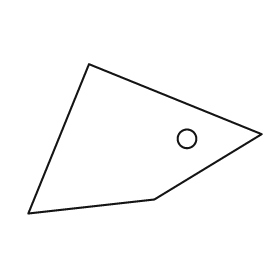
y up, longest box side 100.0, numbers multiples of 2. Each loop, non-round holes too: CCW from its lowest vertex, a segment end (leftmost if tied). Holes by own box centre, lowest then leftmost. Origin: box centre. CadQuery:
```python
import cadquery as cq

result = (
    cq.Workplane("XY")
    .moveTo(-50.0, -32.0)
    .lineTo(4.0, -26.0)
    .lineTo(50.0, 2.0)
    .lineTo(-24.0, 32.0)
    .close()
    .moveTo(18.0, 0.0)
    .circle(4.0)
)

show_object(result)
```